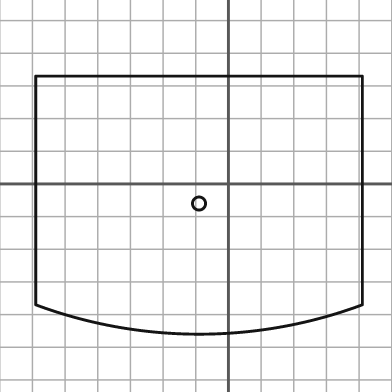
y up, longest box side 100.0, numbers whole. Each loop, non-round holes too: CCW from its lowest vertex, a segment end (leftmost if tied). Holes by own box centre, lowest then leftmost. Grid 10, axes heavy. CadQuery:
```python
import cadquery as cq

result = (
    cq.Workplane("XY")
    .moveTo(-59.0, -37.0)
    .threePointArc((-9.0, -46.0), (41.0, -37.0))
    .lineTo(41.0, 33.0)
    .lineTo(-59.0, 33.0)
    .close()
    .moveTo(-9.0, -6.0)
    .circle(2.0)
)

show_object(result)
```